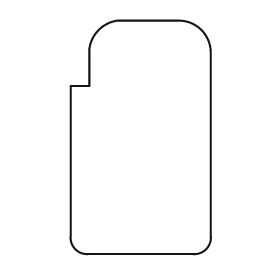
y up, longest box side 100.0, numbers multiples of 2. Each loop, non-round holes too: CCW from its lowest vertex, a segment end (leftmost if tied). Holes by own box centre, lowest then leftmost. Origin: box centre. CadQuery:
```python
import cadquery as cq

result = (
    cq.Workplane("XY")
    .moveTo(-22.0, -50.0)
    .lineTo(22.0, -50.0)
    .threePointArc((28.0, -48.0), (30.0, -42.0))
    .lineTo(30.0, 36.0)
    .threePointArc((26.0, 46.0), (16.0, 50.0))
    .lineTo(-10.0, 50.0)
    .threePointArc((-18.0, 46.0), (-22.0, 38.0))
    .lineTo(-22.0, 22.0)
    .lineTo(-30.0, 22.0)
    .lineTo(-30.0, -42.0)
    .threePointArc((-28.0, -48.0), (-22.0, -50.0))
    .close()
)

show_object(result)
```